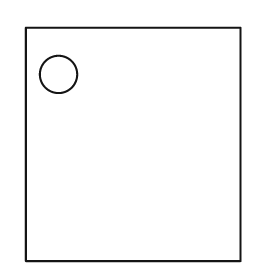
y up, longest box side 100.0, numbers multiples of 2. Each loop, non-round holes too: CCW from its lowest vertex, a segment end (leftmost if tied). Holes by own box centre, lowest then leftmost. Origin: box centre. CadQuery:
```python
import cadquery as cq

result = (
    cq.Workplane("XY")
    .moveTo(-46.0, -50.0)
    .lineTo(46.0, -50.0)
    .lineTo(46.0, 50.0)
    .lineTo(-46.0, 50.0)
    .close()
    .moveTo(-32.0, 30.0)
    .circle(8.0)
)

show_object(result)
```